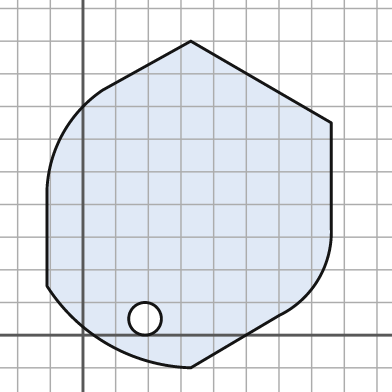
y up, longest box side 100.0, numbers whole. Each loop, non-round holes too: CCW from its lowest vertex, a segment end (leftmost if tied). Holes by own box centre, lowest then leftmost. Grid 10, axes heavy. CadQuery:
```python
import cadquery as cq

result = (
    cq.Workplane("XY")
    .moveTo(33.0, -10.0)
    .lineTo(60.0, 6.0)
    .threePointArc((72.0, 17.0), (76.0, 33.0))
    .lineTo(76.0, 65.0)
    .lineTo(33.0, 90.0)
    .lineTo(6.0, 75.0)
    .threePointArc((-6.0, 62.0), (-11.0, 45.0))
    .lineTo(-11.0, 15.0)
    .threePointArc((8.0, -3.0), (33.0, -10.0))
    .close()
    .moveTo(19.0, 5.0)
    .circle(5.0)
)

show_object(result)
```